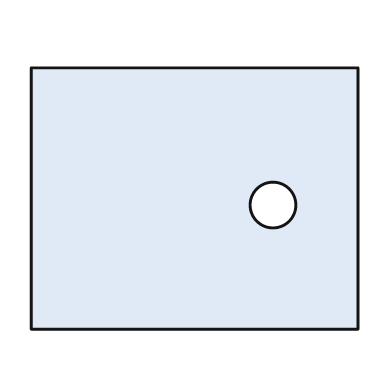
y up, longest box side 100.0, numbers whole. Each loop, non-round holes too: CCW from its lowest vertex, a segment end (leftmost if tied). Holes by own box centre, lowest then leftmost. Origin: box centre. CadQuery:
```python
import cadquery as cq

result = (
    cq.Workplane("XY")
    .moveTo(-50.0, -40.0)
    .lineTo(50.0, -40.0)
    .lineTo(50.0, 40.0)
    .lineTo(-50.0, 40.0)
    .close()
    .moveTo(24.0, -2.0)
    .circle(7.0)
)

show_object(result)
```